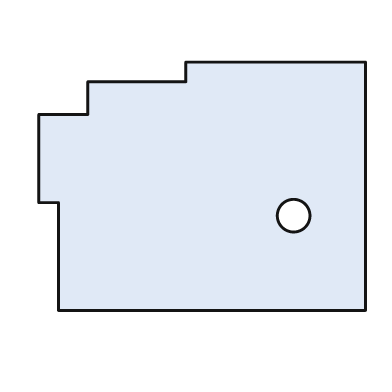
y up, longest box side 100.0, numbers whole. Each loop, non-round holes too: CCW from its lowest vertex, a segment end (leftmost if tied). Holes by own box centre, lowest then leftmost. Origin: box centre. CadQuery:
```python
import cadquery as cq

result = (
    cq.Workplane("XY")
    .moveTo(-44.0, -38.0)
    .lineTo(50.0, -38.0)
    .lineTo(50.0, 38.0)
    .lineTo(-5.0, 38.0)
    .lineTo(-5.0, 32.0)
    .lineTo(-35.0, 32.0)
    .lineTo(-35.0, 22.0)
    .lineTo(-50.0, 22.0)
    .lineTo(-50.0, -5.0)
    .lineTo(-44.0, -5.0)
    .close()
    .moveTo(28.0, -9.0)
    .circle(5.0)
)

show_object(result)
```